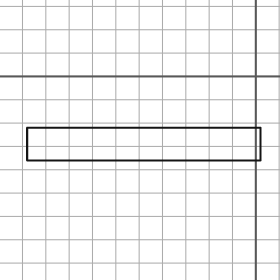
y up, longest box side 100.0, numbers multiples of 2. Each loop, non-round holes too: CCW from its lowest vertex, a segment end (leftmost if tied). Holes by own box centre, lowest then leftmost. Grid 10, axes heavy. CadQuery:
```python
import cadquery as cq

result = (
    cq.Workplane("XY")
    .moveTo(-98.0, -36.0)
    .lineTo(2.0, -36.0)
    .lineTo(2.0, -22.0)
    .lineTo(-98.0, -22.0)
    .close()
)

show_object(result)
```